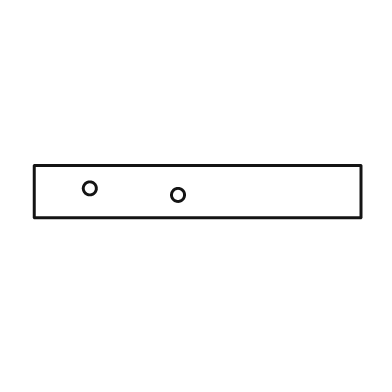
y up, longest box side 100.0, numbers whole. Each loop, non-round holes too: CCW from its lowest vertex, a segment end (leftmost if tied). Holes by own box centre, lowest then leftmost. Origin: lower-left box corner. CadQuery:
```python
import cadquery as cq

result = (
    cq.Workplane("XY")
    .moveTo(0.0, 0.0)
    .lineTo(100.0, 0.0)
    .lineTo(100.0, 16.0)
    .lineTo(0.0, 16.0)
    .close()
    .moveTo(44.0, 7.0)
    .circle(2.0)
    .moveTo(17.0, 9.0)
    .circle(2.0)
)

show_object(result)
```